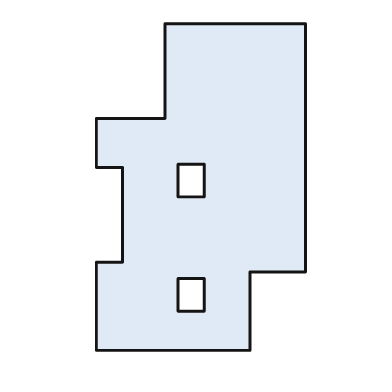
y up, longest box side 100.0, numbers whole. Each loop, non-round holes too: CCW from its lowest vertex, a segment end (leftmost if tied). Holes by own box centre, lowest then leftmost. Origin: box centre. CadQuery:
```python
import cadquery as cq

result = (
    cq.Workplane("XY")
    .moveTo(-32.0, -50.0)
    .lineTo(15.0, -50.0)
    .lineTo(15.0, -26.0)
    .lineTo(32.0, -26.0)
    .lineTo(32.0, 50.0)
    .lineTo(-11.0, 50.0)
    .lineTo(-11.0, 21.0)
    .lineTo(-32.0, 21.0)
    .lineTo(-32.0, 6.0)
    .lineTo(-24.0, 6.0)
    .lineTo(-24.0, -23.0)
    .lineTo(-32.0, -23.0)
    .close()
    .moveTo(-7.0, -38.0)
    .lineTo(1.0, -38.0)
    .lineTo(1.0, -28.0)
    .lineTo(-7.0, -28.0)
    .close()
    .moveTo(-7.0, -3.0)
    .lineTo(1.0, -3.0)
    .lineTo(1.0, 7.0)
    .lineTo(-7.0, 7.0)
    .close()
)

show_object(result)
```